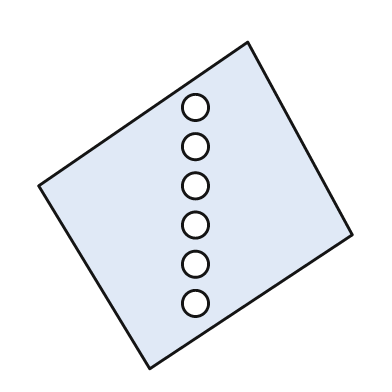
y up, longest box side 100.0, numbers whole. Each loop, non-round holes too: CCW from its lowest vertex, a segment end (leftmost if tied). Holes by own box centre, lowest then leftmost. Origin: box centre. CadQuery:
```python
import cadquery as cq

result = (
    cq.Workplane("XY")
    .moveTo(-14.0, -50.0)
    .lineTo(48.0, -9.0)
    .lineTo(16.0, 50.0)
    .lineTo(-48.0, 6.0)
    .close()
    .moveTo(0.0, -30.0)
    .circle(4.0)
    .moveTo(0.0, -18.0)
    .circle(4.0)
    .moveTo(0.0, -6.0)
    .circle(4.0)
    .moveTo(0.0, 6.0)
    .circle(4.0)
    .moveTo(0.0, 18.0)
    .circle(4.0)
    .moveTo(0.0, 30.0)
    .circle(4.0)
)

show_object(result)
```